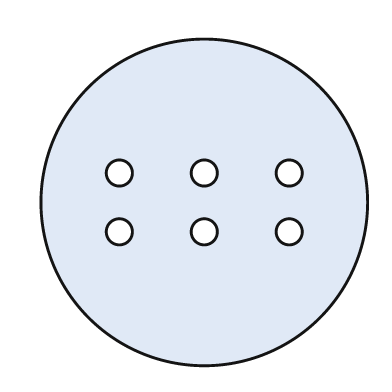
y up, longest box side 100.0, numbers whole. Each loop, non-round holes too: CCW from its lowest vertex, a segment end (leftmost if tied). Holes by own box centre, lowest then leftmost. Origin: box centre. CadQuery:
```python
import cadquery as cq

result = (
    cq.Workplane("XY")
    .moveTo(0.0, 0.0)
    .circle(50.0)
    .moveTo(-26.0, -9.0)
    .circle(4.0)
    .moveTo(0.0, -9.0)
    .circle(4.0)
    .moveTo(26.0, -9.0)
    .circle(4.0)
    .moveTo(-26.0, 9.0)
    .circle(4.0)
    .moveTo(0.0, 9.0)
    .circle(4.0)
    .moveTo(26.0, 9.0)
    .circle(4.0)
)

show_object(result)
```